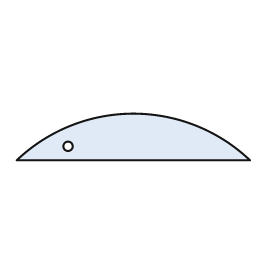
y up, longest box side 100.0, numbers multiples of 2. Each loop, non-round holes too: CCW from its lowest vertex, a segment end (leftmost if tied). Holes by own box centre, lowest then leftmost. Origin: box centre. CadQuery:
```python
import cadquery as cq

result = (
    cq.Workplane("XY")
    .moveTo(-50.0, -10.0)
    .lineTo(50.0, -10.0)
    .threePointArc((0.0, 10.0), (-50.0, -10.0))
    .close()
    .moveTo(-28.0, -4.0)
    .circle(2.0)
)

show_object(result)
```